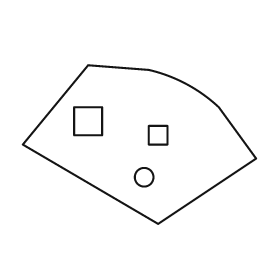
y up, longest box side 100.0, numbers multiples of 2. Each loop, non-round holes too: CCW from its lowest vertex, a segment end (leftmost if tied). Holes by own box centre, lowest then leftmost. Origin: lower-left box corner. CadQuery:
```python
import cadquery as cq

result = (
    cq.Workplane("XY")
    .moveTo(58.0, 0.0)
    .lineTo(100.0, 28.0)
    .lineTo(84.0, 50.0)
    .threePointArc((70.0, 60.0), (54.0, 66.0))
    .lineTo(28.0, 68.0)
    .lineTo(0.0, 34.0)
    .close()
    .moveTo(52.0, 20.0)
    .circle(4.0)
    .moveTo(54.0, 34.0)
    .lineTo(62.0, 34.0)
    .lineTo(62.0, 42.0)
    .lineTo(54.0, 42.0)
    .close()
    .moveTo(22.0, 38.0)
    .lineTo(34.0, 38.0)
    .lineTo(34.0, 50.0)
    .lineTo(22.0, 50.0)
    .close()
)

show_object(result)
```